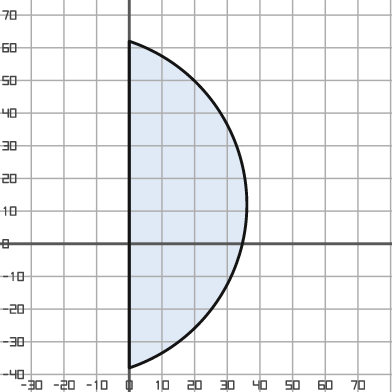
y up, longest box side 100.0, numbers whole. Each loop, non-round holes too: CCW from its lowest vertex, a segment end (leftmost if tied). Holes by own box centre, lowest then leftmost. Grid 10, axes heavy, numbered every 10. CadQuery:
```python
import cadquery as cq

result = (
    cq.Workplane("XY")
    .moveTo(0.0, -38.0)
    .threePointArc((36.0, 12.0), (0.0, 62.0))
    .close()
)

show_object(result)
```